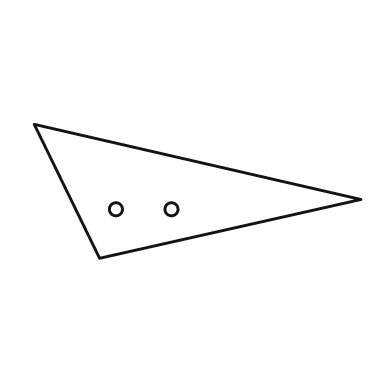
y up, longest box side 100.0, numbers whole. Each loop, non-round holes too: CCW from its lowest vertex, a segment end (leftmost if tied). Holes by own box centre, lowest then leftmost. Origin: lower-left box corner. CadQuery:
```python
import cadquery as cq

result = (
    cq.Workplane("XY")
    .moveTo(20.0, 0.0)
    .lineTo(100.0, 18.0)
    .lineTo(0.0, 41.0)
    .close()
    .moveTo(25.0, 15.0)
    .circle(2.0)
    .moveTo(42.0, 15.0)
    .circle(2.0)
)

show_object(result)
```